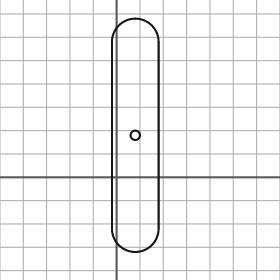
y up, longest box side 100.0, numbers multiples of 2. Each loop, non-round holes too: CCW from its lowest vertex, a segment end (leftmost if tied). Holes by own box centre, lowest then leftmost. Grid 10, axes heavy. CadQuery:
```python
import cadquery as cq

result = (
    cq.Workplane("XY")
    .moveTo(-2.0, -22.0)
    .threePointArc((8.0, -32.0), (18.0, -22.0))
    .lineTo(18.0, 58.0)
    .threePointArc((8.0, 68.0), (-2.0, 58.0))
    .close()
    .moveTo(8.0, 18.0)
    .circle(2.0)
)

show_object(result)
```